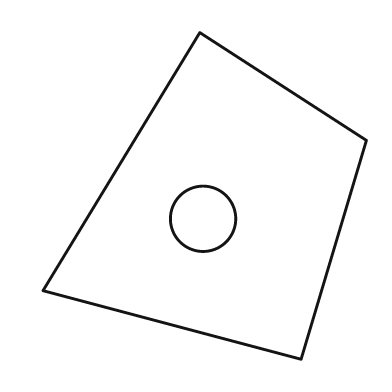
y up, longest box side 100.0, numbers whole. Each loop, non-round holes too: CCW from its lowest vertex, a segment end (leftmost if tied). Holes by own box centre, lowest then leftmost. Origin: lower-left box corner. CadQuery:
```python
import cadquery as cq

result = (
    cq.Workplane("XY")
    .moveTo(79.0, 0.0)
    .lineTo(99.0, 67.0)
    .lineTo(48.0, 100.0)
    .lineTo(0.0, 21.0)
    .close()
    .moveTo(49.0, 43.0)
    .circle(10.0)
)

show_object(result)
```